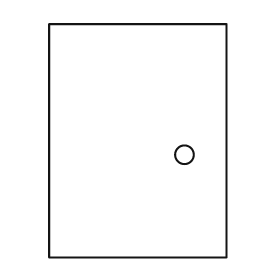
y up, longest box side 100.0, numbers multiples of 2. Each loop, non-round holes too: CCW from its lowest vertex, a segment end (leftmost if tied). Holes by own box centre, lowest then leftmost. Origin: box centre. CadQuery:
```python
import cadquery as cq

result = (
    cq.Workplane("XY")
    .moveTo(-38.0, -50.0)
    .lineTo(38.0, -50.0)
    .lineTo(38.0, 50.0)
    .lineTo(-38.0, 50.0)
    .close()
    .moveTo(20.0, -6.0)
    .circle(4.0)
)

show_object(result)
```